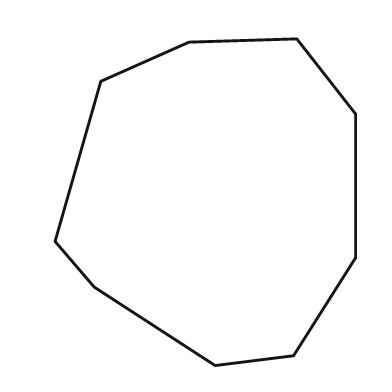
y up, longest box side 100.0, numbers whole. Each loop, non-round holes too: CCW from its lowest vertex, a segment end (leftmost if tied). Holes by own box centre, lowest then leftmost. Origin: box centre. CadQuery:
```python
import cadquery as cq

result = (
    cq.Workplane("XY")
    .moveTo(3.0, -50.0)
    .lineTo(27.0, -47.0)
    .lineTo(46.0, -17.0)
    .lineTo(46.0, 27.0)
    .lineTo(28.0, 50.0)
    .lineTo(-5.0, 49.0)
    .lineTo(-32.0, 37.0)
    .lineTo(-46.0, -12.0)
    .lineTo(-34.0, -26.0)
    .close()
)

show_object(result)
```